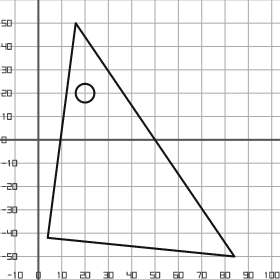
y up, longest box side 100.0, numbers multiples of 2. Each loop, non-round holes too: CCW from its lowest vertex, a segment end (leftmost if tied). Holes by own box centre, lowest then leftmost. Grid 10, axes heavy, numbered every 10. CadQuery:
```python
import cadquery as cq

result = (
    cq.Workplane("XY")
    .moveTo(84.0, -50.0)
    .lineTo(16.0, 50.0)
    .lineTo(4.0, -42.0)
    .close()
    .moveTo(20.0, 20.0)
    .circle(4.0)
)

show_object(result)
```